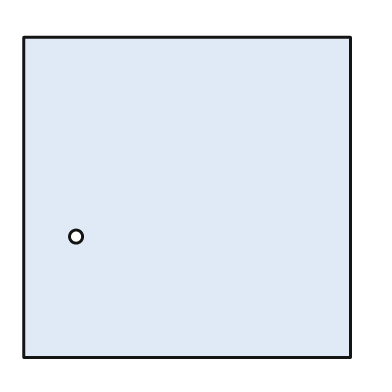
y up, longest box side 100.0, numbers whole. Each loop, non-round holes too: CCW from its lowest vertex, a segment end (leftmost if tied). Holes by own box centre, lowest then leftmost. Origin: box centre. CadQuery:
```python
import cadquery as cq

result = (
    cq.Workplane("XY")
    .moveTo(-50.0, -49.0)
    .lineTo(50.0, -49.0)
    .lineTo(50.0, 49.0)
    .lineTo(-50.0, 49.0)
    .close()
    .moveTo(-34.0, -12.0)
    .circle(2.0)
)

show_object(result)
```